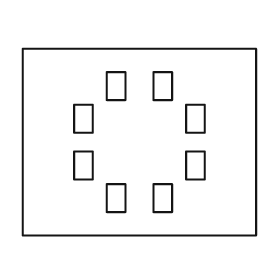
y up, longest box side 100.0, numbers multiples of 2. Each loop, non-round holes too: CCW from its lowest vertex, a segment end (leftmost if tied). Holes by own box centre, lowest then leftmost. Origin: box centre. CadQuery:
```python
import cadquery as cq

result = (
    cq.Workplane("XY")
    .moveTo(-50.0, -40.0)
    .lineTo(50.0, -40.0)
    .lineTo(50.0, 40.0)
    .lineTo(-50.0, 40.0)
    .close()
    .moveTo(-14.0, -30.0)
    .lineTo(-6.0, -30.0)
    .lineTo(-6.0, -18.0)
    .lineTo(-14.0, -18.0)
    .close()
    .moveTo(6.0, -30.0)
    .lineTo(14.0, -30.0)
    .lineTo(14.0, -18.0)
    .lineTo(6.0, -18.0)
    .close()
    .moveTo(-28.0, -16.0)
    .lineTo(-20.0, -16.0)
    .lineTo(-20.0, -4.0)
    .lineTo(-28.0, -4.0)
    .close()
    .moveTo(20.0, -16.0)
    .lineTo(28.0, -16.0)
    .lineTo(28.0, -4.0)
    .lineTo(20.0, -4.0)
    .close()
    .moveTo(-28.0, 4.0)
    .lineTo(-20.0, 4.0)
    .lineTo(-20.0, 16.0)
    .lineTo(-28.0, 16.0)
    .close()
    .moveTo(20.0, 4.0)
    .lineTo(28.0, 4.0)
    .lineTo(28.0, 16.0)
    .lineTo(20.0, 16.0)
    .close()
    .moveTo(-14.0, 18.0)
    .lineTo(-6.0, 18.0)
    .lineTo(-6.0, 30.0)
    .lineTo(-14.0, 30.0)
    .close()
    .moveTo(6.0, 18.0)
    .lineTo(14.0, 18.0)
    .lineTo(14.0, 30.0)
    .lineTo(6.0, 30.0)
    .close()
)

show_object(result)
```